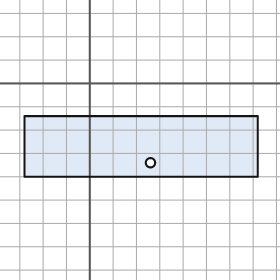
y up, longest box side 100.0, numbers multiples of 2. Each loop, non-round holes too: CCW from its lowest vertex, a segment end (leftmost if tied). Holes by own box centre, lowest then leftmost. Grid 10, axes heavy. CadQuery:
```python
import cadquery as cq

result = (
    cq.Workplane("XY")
    .moveTo(-28.0, -40.0)
    .lineTo(72.0, -40.0)
    .lineTo(72.0, -14.0)
    .lineTo(-28.0, -14.0)
    .close()
    .moveTo(26.0, -34.0)
    .circle(2.0)
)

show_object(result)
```